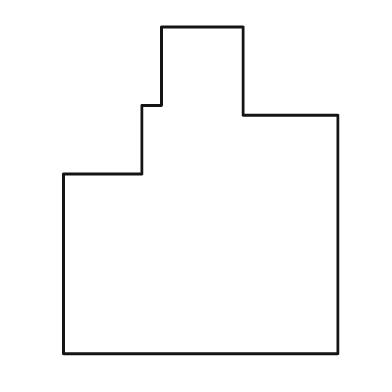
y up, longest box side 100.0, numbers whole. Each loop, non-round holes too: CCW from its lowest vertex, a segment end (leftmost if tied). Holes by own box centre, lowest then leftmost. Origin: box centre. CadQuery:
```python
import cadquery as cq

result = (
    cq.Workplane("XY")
    .moveTo(-42.0, -50.0)
    .lineTo(42.0, -50.0)
    .lineTo(42.0, 23.0)
    .lineTo(13.0, 23.0)
    .lineTo(13.0, 50.0)
    .lineTo(-12.0, 50.0)
    .lineTo(-12.0, 26.0)
    .lineTo(-18.0, 26.0)
    .lineTo(-18.0, 5.0)
    .lineTo(-42.0, 5.0)
    .close()
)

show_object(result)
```